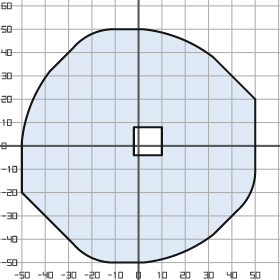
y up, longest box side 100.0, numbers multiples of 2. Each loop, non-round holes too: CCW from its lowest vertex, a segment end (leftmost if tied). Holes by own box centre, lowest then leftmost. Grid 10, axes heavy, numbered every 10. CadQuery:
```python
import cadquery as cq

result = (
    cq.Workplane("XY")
    .moveTo(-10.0, -50.0)
    .lineTo(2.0, -50.0)
    .threePointArc((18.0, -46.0), (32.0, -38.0))
    .lineTo(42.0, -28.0)
    .threePointArc((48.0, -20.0), (50.0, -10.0))
    .lineTo(50.0, 20.0)
    .lineTo(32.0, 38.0)
    .threePointArc((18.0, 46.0), (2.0, 50.0))
    .lineTo(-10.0, 50.0)
    .threePointArc((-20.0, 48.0), (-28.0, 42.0))
    .lineTo(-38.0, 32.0)
    .threePointArc((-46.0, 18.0), (-50.0, 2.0))
    .lineTo(-50.0, -20.0)
    .lineTo(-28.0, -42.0)
    .threePointArc((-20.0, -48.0), (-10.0, -50.0))
    .close()
    .moveTo(-2.0, -4.0)
    .lineTo(10.0, -4.0)
    .lineTo(10.0, 8.0)
    .lineTo(-2.0, 8.0)
    .close()
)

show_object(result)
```